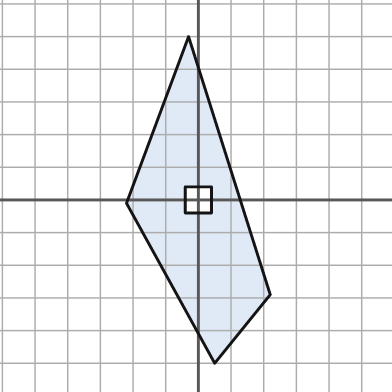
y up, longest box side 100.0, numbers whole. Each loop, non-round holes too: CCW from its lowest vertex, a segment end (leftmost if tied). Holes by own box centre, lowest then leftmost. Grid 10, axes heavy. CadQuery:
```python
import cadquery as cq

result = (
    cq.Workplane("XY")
    .moveTo(5.0, -50.0)
    .lineTo(22.0, -29.0)
    .lineTo(-3.0, 50.0)
    .lineTo(-22.0, -1.0)
    .close()
    .moveTo(-4.0, -4.0)
    .lineTo(4.0, -4.0)
    .lineTo(4.0, 4.0)
    .lineTo(-4.0, 4.0)
    .close()
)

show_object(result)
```